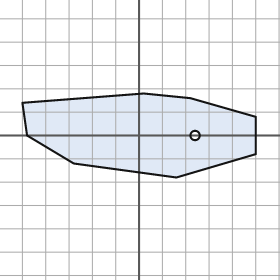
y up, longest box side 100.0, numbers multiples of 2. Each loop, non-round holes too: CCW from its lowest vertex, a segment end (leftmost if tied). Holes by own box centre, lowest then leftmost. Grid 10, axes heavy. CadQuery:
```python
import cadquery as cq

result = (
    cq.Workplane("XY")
    .moveTo(16.0, -18.0)
    .lineTo(50.0, -8.0)
    .lineTo(50.0, 8.0)
    .lineTo(22.0, 16.0)
    .lineTo(2.0, 18.0)
    .lineTo(-50.0, 14.0)
    .lineTo(-48.0, 0.0)
    .lineTo(-28.0, -12.0)
    .close()
    .moveTo(24.0, 0.0)
    .circle(2.0)
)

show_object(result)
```